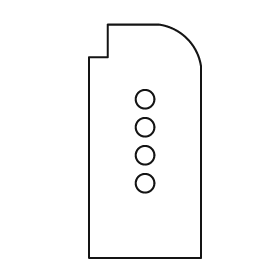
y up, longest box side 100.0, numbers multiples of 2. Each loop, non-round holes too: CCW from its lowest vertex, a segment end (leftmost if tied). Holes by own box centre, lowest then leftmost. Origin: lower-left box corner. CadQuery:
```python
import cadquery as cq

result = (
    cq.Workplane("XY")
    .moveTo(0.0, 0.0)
    .lineTo(48.0, 0.0)
    .lineTo(48.0, 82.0)
    .threePointArc((42.0, 94.0), (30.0, 100.0))
    .lineTo(8.0, 100.0)
    .lineTo(8.0, 86.0)
    .lineTo(0.0, 86.0)
    .close()
    .moveTo(24.0, 32.0)
    .circle(4.0)
    .moveTo(24.0, 44.0)
    .circle(4.0)
    .moveTo(24.0, 56.0)
    .circle(4.0)
    .moveTo(24.0, 68.0)
    .circle(4.0)
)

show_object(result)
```